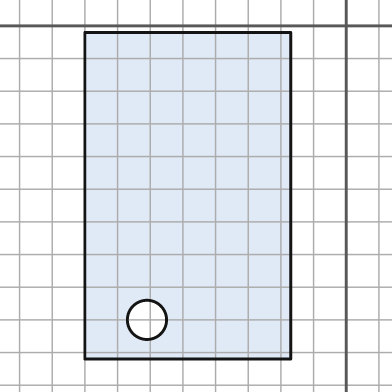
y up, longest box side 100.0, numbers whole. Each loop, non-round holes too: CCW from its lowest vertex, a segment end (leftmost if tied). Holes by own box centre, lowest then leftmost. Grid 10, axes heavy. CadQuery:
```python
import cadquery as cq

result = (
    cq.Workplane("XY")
    .moveTo(-80.0, -102.0)
    .lineTo(-17.0, -102.0)
    .lineTo(-17.0, -2.0)
    .lineTo(-80.0, -2.0)
    .close()
    .moveTo(-61.0, -90.0)
    .circle(6.0)
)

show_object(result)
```